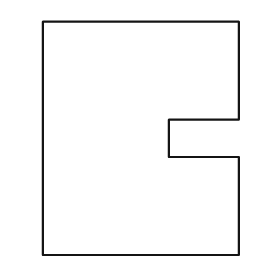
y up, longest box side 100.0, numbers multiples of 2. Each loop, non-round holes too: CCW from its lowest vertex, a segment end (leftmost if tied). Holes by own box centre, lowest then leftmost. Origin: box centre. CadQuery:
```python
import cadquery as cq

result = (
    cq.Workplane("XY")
    .moveTo(-42.0, -50.0)
    .lineTo(42.0, -50.0)
    .lineTo(42.0, -8.0)
    .lineTo(12.0, -8.0)
    .lineTo(12.0, 8.0)
    .lineTo(42.0, 8.0)
    .lineTo(42.0, 50.0)
    .lineTo(-42.0, 50.0)
    .close()
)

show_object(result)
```